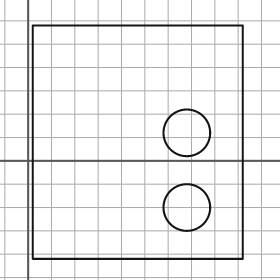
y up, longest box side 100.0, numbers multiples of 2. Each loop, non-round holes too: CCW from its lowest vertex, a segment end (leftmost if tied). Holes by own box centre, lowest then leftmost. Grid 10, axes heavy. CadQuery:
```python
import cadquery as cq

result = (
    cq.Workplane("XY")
    .moveTo(2.0, -42.0)
    .lineTo(92.0, -42.0)
    .lineTo(92.0, 58.0)
    .lineTo(2.0, 58.0)
    .close()
    .moveTo(68.0, -20.0)
    .circle(10.0)
    .moveTo(68.0, 12.0)
    .circle(10.0)
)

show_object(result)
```